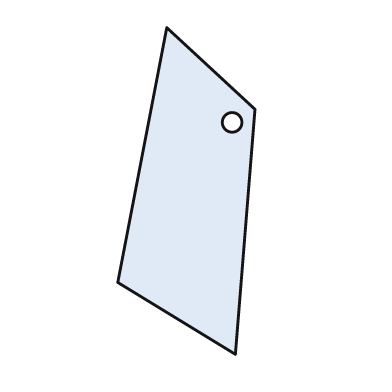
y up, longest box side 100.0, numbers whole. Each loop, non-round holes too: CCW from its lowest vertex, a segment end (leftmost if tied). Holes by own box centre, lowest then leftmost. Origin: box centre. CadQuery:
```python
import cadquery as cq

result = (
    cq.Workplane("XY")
    .moveTo(15.0, -50.0)
    .lineTo(21.0, 25.0)
    .lineTo(-6.0, 50.0)
    .lineTo(-21.0, -28.0)
    .close()
    .moveTo(14.0, 21.0)
    .circle(3.0)
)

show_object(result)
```